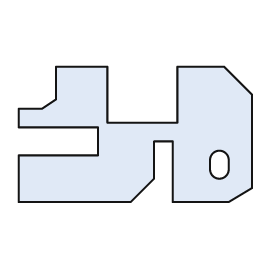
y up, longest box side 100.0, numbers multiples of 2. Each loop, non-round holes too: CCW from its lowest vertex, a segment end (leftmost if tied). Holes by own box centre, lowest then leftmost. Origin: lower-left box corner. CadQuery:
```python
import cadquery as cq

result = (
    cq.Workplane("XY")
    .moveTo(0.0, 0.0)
    .lineTo(48.0, 0.0)
    .lineTo(58.0, 10.0)
    .lineTo(58.0, 26.0)
    .lineTo(66.0, 26.0)
    .lineTo(66.0, 0.0)
    .lineTo(90.0, 0.0)
    .lineTo(100.0, 6.0)
    .lineTo(100.0, 46.0)
    .lineTo(88.0, 58.0)
    .lineTo(68.0, 58.0)
    .lineTo(68.0, 34.0)
    .lineTo(38.0, 34.0)
    .lineTo(38.0, 58.0)
    .lineTo(16.0, 58.0)
    .lineTo(16.0, 44.0)
    .lineTo(10.0, 40.0)
    .lineTo(0.0, 40.0)
    .lineTo(0.0, 32.0)
    .lineTo(34.0, 32.0)
    .lineTo(34.0, 20.0)
    .lineTo(0.0, 20.0)
    .close()
    .moveTo(82.0, 14.0)
    .threePointArc((86.0, 10.0), (90.0, 14.0))
    .lineTo(90.0, 18.0)
    .threePointArc((86.0, 22.0), (82.0, 18.0))
    .close()
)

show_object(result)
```